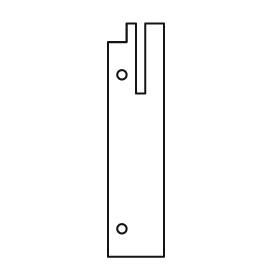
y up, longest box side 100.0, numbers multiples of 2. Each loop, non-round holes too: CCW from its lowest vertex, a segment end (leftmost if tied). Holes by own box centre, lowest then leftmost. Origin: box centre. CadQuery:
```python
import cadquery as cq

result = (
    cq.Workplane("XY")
    .moveTo(-12.0, -50.0)
    .lineTo(12.0, -50.0)
    .lineTo(12.0, 50.0)
    .lineTo(4.0, 50.0)
    .lineTo(4.0, 20.0)
    .lineTo(0.0, 20.0)
    .lineTo(0.0, 50.0)
    .lineTo(-4.0, 50.0)
    .lineTo(-4.0, 42.0)
    .lineTo(-12.0, 42.0)
    .close()
    .moveTo(-6.0, -38.0)
    .circle(2.0)
    .moveTo(-6.0, 28.0)
    .circle(2.0)
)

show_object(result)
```